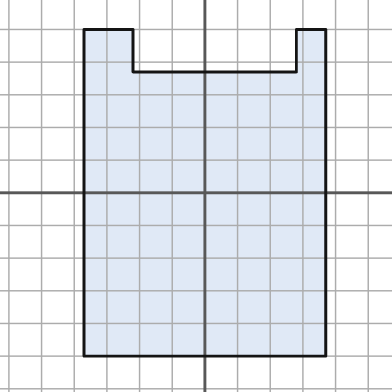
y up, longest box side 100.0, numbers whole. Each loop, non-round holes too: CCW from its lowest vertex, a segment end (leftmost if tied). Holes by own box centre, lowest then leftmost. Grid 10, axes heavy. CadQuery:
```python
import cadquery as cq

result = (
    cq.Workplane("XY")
    .moveTo(-37.0, -50.0)
    .lineTo(37.0, -50.0)
    .lineTo(37.0, 50.0)
    .lineTo(28.0, 50.0)
    .lineTo(28.0, 37.0)
    .lineTo(-22.0, 37.0)
    .lineTo(-22.0, 50.0)
    .lineTo(-37.0, 50.0)
    .close()
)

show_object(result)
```